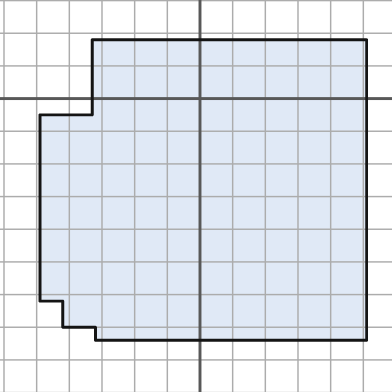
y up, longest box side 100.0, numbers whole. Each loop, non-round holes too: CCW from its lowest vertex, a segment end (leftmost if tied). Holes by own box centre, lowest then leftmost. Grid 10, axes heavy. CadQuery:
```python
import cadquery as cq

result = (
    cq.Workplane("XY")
    .moveTo(-32.0, -74.0)
    .lineTo(51.0, -74.0)
    .lineTo(51.0, 18.0)
    .lineTo(-33.0, 18.0)
    .lineTo(-33.0, -5.0)
    .lineTo(-49.0, -5.0)
    .lineTo(-49.0, -62.0)
    .lineTo(-42.0, -62.0)
    .lineTo(-42.0, -70.0)
    .lineTo(-32.0, -70.0)
    .close()
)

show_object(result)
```